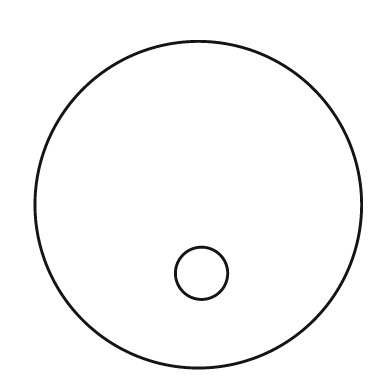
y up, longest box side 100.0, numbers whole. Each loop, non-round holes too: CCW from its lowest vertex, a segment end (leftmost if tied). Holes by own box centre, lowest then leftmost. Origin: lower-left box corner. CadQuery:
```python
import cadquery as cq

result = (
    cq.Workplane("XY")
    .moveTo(50.0, 50.0)
    .circle(50.0)
    .moveTo(51.0, 29.0)
    .circle(8.0)
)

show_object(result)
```